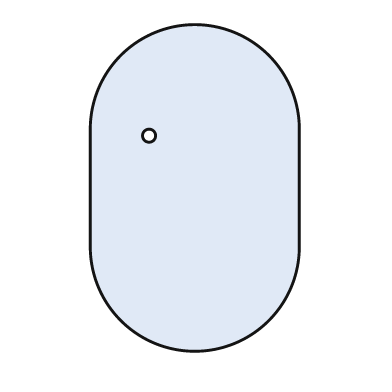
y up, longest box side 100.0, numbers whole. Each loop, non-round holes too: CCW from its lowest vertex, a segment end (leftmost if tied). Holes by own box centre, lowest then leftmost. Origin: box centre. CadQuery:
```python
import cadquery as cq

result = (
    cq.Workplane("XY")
    .moveTo(-32.0, -18.0)
    .threePointArc((0.0, -50.0), (32.0, -18.0))
    .lineTo(32.0, 18.0)
    .threePointArc((0.0, 50.0), (-32.0, 18.0))
    .close()
    .moveTo(-14.0, 16.0)
    .circle(2.0)
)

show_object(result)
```